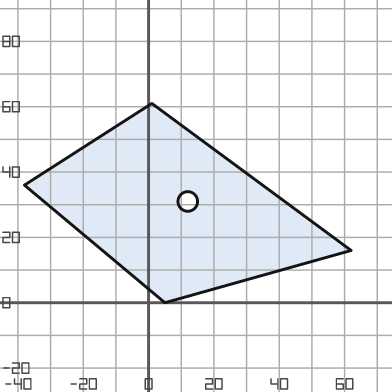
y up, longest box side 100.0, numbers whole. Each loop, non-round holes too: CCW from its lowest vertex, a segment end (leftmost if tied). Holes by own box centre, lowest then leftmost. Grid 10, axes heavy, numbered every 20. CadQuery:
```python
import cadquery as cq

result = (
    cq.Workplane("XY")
    .moveTo(5.0, 0.0)
    .lineTo(62.0, 16.0)
    .lineTo(1.0, 61.0)
    .lineTo(-38.0, 36.0)
    .close()
    .moveTo(12.0, 31.0)
    .circle(3.0)
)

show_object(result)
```